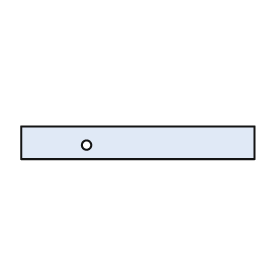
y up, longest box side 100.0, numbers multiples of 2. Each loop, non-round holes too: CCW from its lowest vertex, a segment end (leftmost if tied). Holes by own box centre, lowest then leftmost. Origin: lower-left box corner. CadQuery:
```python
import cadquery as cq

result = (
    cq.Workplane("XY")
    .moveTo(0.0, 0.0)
    .lineTo(100.0, 0.0)
    .lineTo(100.0, 14.0)
    .lineTo(0.0, 14.0)
    .close()
    .moveTo(28.0, 6.0)
    .circle(2.0)
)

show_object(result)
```